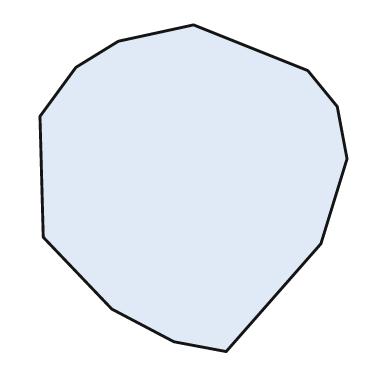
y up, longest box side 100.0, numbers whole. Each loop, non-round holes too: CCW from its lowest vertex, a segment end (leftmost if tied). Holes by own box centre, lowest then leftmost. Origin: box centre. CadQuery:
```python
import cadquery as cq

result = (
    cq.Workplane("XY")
    .moveTo(10.0, -50.0)
    .lineTo(39.0, -17.0)
    .lineTo(47.0, 9.0)
    .lineTo(44.0, 25.0)
    .lineTo(35.0, 36.0)
    .lineTo(0.0, 50.0)
    .lineTo(-23.0, 45.0)
    .lineTo(-36.0, 37.0)
    .lineTo(-47.0, 22.0)
    .lineTo(-46.0, -15.0)
    .lineTo(-25.0, -37.0)
    .lineTo(-6.0, -47.0)
    .close()
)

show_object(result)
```